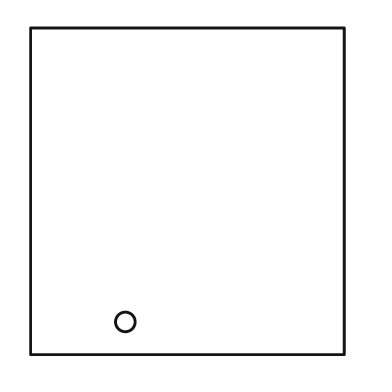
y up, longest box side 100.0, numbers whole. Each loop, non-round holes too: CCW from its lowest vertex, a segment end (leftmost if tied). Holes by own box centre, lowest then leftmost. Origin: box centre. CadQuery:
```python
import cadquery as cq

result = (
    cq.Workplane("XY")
    .moveTo(-48.0, -50.0)
    .lineTo(48.0, -50.0)
    .lineTo(48.0, 50.0)
    .lineTo(-48.0, 50.0)
    .close()
    .moveTo(-19.0, -40.0)
    .circle(3.0)
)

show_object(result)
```